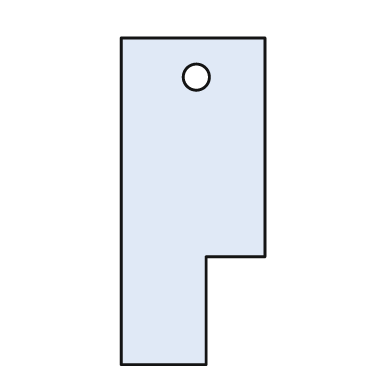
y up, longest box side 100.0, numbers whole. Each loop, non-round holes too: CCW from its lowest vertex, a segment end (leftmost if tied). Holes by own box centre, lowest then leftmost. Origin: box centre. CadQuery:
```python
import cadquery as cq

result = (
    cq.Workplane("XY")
    .moveTo(-22.0, -50.0)
    .lineTo(4.0, -50.0)
    .lineTo(4.0, -17.0)
    .lineTo(22.0, -17.0)
    .lineTo(22.0, 50.0)
    .lineTo(-22.0, 50.0)
    .close()
    .moveTo(1.0, 38.0)
    .circle(4.0)
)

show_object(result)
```